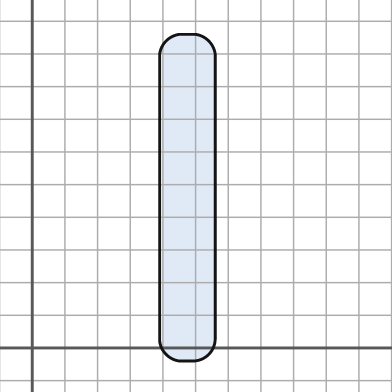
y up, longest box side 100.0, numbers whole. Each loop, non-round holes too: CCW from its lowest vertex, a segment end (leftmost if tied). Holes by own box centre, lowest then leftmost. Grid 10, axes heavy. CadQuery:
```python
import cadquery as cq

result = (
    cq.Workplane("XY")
    .moveTo(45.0, -4.0)
    .lineTo(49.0, -4.0)
    .threePointArc((54.0, -2.0), (56.0, 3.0))
    .lineTo(56.0, 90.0)
    .threePointArc((54.0, 94.0), (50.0, 96.0))
    .lineTo(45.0, 96.0)
    .threePointArc((41.0, 94.0), (39.0, 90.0))
    .lineTo(39.0, 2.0)
    .threePointArc((41.0, -2.0), (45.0, -4.0))
    .close()
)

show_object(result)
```